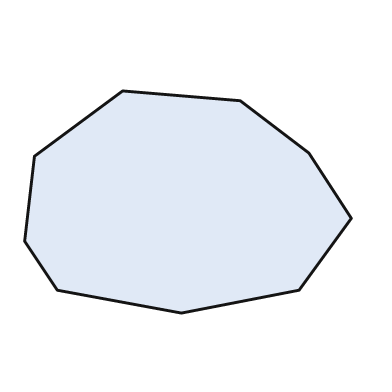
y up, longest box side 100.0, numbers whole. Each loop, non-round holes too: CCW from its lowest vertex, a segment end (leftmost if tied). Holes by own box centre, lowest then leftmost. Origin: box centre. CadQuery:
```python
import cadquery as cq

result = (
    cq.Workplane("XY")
    .moveTo(-2.0, -34.0)
    .lineTo(34.0, -27.0)
    .lineTo(50.0, -5.0)
    .lineTo(37.0, 15.0)
    .lineTo(16.0, 31.0)
    .lineTo(-20.0, 34.0)
    .lineTo(-47.0, 14.0)
    .lineTo(-50.0, -12.0)
    .lineTo(-40.0, -27.0)
    .close()
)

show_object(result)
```